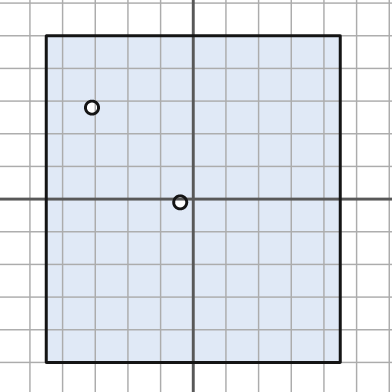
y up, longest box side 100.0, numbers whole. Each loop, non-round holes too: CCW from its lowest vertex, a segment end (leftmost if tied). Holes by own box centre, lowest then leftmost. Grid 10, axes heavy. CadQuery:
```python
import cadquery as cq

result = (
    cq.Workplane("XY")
    .moveTo(-45.0, -50.0)
    .lineTo(45.0, -50.0)
    .lineTo(45.0, 50.0)
    .lineTo(-45.0, 50.0)
    .close()
    .moveTo(-4.0, -1.0)
    .circle(2.0)
    .moveTo(-31.0, 28.0)
    .circle(2.0)
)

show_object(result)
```